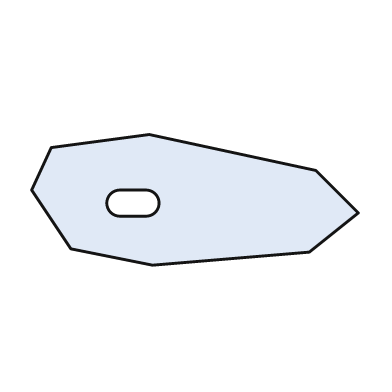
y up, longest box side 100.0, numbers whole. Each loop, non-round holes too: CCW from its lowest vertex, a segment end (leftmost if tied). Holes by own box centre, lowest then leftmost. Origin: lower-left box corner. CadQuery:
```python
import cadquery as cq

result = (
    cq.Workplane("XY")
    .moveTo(37.0, 0.0)
    .lineTo(85.0, 4.0)
    .lineTo(100.0, 16.0)
    .lineTo(87.0, 29.0)
    .lineTo(36.0, 40.0)
    .lineTo(6.0, 36.0)
    .lineTo(0.0, 23.0)
    .lineTo(12.0, 5.0)
    .close()
    .moveTo(27.0, 15.0)
    .lineTo(35.0, 15.0)
    .threePointArc((39.0, 19.0), (35.0, 23.0))
    .lineTo(27.0, 23.0)
    .threePointArc((23.0, 19.0), (27.0, 15.0))
    .close()
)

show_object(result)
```